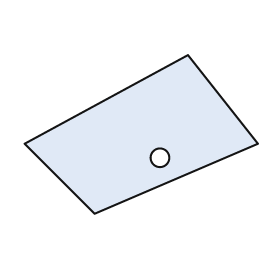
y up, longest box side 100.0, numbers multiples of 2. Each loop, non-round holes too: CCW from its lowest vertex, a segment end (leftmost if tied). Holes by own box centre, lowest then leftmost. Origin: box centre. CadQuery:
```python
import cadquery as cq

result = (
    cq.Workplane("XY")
    .moveTo(-20.0, -34.0)
    .lineTo(50.0, -4.0)
    .lineTo(20.0, 34.0)
    .lineTo(-50.0, -4.0)
    .close()
    .moveTo(8.0, -10.0)
    .circle(4.0)
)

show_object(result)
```